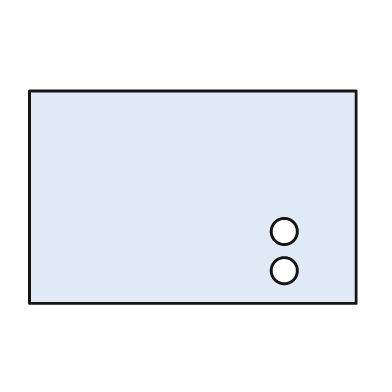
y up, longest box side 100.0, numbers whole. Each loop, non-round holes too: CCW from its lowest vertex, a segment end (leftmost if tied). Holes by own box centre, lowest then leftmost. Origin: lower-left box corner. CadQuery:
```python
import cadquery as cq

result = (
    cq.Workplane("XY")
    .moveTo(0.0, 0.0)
    .lineTo(100.0, 0.0)
    .lineTo(100.0, 65.0)
    .lineTo(0.0, 65.0)
    .close()
    .moveTo(78.0, 10.0)
    .circle(4.0)
    .moveTo(78.0, 22.0)
    .circle(4.0)
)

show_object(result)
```